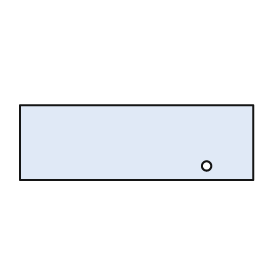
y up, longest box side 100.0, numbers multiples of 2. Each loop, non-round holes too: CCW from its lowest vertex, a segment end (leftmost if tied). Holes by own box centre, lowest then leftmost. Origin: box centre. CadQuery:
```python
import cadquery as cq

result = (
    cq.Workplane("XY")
    .moveTo(-50.0, -16.0)
    .lineTo(50.0, -16.0)
    .lineTo(50.0, 16.0)
    .lineTo(-50.0, 16.0)
    .close()
    .moveTo(30.0, -10.0)
    .circle(2.0)
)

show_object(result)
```